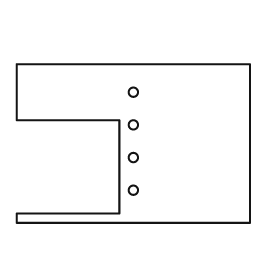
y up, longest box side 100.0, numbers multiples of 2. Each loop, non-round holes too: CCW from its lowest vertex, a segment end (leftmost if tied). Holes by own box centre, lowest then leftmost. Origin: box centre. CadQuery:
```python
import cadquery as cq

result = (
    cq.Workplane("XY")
    .moveTo(-50.0, -34.0)
    .lineTo(50.0, -34.0)
    .lineTo(50.0, 34.0)
    .lineTo(-50.0, 34.0)
    .lineTo(-50.0, 10.0)
    .lineTo(-6.0, 10.0)
    .lineTo(-6.0, -30.0)
    .lineTo(-50.0, -30.0)
    .close()
    .moveTo(0.0, -20.0)
    .circle(2.0)
    .moveTo(0.0, -6.0)
    .circle(2.0)
    .moveTo(0.0, 8.0)
    .circle(2.0)
    .moveTo(0.0, 22.0)
    .circle(2.0)
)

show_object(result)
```